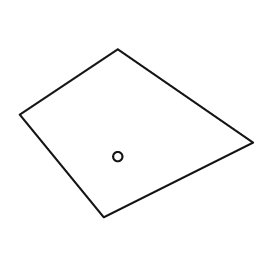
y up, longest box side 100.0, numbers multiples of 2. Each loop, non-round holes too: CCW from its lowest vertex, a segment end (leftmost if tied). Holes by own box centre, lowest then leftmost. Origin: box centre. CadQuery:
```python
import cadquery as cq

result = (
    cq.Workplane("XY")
    .moveTo(-14.0, -36.0)
    .lineTo(50.0, -4.0)
    .lineTo(-8.0, 36.0)
    .lineTo(-50.0, 8.0)
    .close()
    .moveTo(-8.0, -10.0)
    .circle(2.0)
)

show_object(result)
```